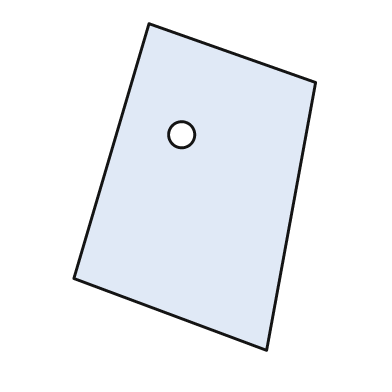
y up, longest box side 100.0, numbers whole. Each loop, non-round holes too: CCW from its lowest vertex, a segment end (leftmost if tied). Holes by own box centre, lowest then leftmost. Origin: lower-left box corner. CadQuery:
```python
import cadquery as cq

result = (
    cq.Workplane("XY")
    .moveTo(59.0, 0.0)
    .lineTo(74.0, 82.0)
    .lineTo(23.0, 100.0)
    .lineTo(0.0, 22.0)
    .close()
    .moveTo(33.0, 66.0)
    .circle(4.0)
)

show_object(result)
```